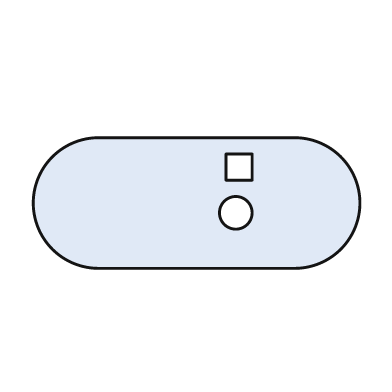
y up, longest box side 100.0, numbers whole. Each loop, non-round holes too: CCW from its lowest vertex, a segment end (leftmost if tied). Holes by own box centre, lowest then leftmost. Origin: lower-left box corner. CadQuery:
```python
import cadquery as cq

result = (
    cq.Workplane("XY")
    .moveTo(20.0, 0.0)
    .lineTo(80.0, 0.0)
    .threePointArc((100.0, 20.0), (80.0, 40.0))
    .lineTo(20.0, 40.0)
    .threePointArc((0.0, 20.0), (20.0, 0.0))
    .close()
    .moveTo(62.0, 17.0)
    .circle(5.0)
    .moveTo(59.0, 27.0)
    .lineTo(67.0, 27.0)
    .lineTo(67.0, 35.0)
    .lineTo(59.0, 35.0)
    .close()
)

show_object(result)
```